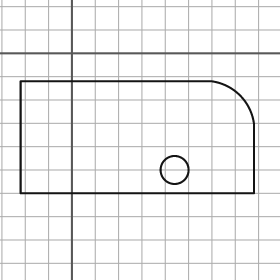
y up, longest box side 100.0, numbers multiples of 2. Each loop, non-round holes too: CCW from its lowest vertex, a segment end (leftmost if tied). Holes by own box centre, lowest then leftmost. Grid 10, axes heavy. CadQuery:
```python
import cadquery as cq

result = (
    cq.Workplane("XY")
    .moveTo(-22.0, -60.0)
    .lineTo(78.0, -60.0)
    .lineTo(78.0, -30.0)
    .threePointArc((72.0, -18.0), (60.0, -12.0))
    .lineTo(-22.0, -12.0)
    .close()
    .moveTo(44.0, -50.0)
    .circle(6.0)
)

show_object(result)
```